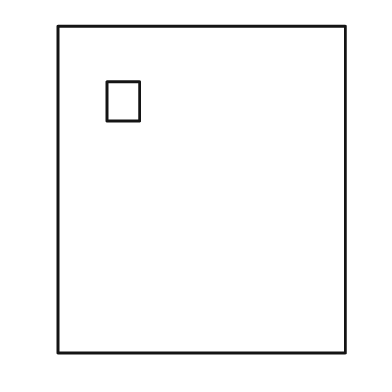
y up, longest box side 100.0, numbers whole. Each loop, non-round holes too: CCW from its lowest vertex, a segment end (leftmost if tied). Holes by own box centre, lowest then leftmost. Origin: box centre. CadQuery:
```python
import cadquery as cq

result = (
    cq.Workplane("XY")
    .moveTo(-44.0, -50.0)
    .lineTo(44.0, -50.0)
    .lineTo(44.0, 50.0)
    .lineTo(-44.0, 50.0)
    .close()
    .moveTo(-29.0, 21.0)
    .lineTo(-19.0, 21.0)
    .lineTo(-19.0, 33.0)
    .lineTo(-29.0, 33.0)
    .close()
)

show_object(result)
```